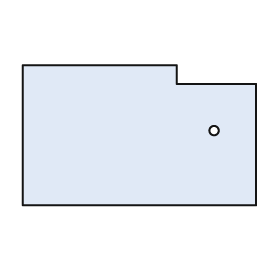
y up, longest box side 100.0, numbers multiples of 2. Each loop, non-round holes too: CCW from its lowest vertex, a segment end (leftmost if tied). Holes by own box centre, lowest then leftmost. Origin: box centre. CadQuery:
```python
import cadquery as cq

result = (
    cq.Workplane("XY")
    .moveTo(-50.0, -30.0)
    .lineTo(50.0, -30.0)
    .lineTo(50.0, 22.0)
    .lineTo(16.0, 22.0)
    .lineTo(16.0, 30.0)
    .lineTo(-50.0, 30.0)
    .close()
    .moveTo(32.0, 2.0)
    .circle(2.0)
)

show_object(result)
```